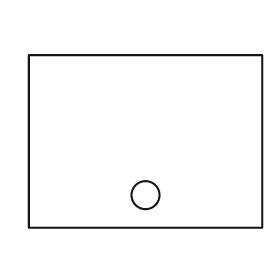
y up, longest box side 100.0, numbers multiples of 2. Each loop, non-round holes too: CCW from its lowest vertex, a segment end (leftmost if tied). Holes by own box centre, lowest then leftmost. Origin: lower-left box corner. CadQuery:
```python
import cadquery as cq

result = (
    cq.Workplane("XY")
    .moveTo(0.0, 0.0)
    .lineTo(100.0, 0.0)
    .lineTo(100.0, 74.0)
    .lineTo(0.0, 74.0)
    .close()
    .moveTo(50.0, 14.0)
    .circle(6.0)
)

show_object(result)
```